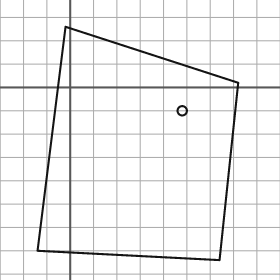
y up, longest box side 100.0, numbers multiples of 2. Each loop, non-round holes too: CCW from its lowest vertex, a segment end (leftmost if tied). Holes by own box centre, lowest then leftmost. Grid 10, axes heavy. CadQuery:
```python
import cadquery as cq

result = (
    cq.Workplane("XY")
    .moveTo(64.0, -74.0)
    .lineTo(72.0, 2.0)
    .lineTo(-2.0, 26.0)
    .lineTo(-14.0, -70.0)
    .close()
    .moveTo(48.0, -10.0)
    .circle(2.0)
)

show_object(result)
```